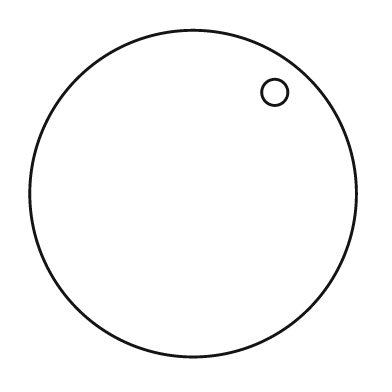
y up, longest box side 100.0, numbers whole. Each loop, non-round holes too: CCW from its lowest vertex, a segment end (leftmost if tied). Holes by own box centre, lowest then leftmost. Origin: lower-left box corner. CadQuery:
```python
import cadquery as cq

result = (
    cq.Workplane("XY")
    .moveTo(50.0, 50.0)
    .circle(50.0)
    .moveTo(75.0, 81.0)
    .circle(4.0)
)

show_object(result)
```